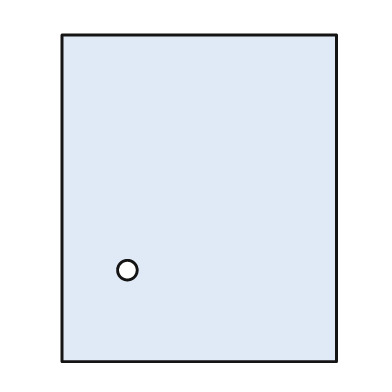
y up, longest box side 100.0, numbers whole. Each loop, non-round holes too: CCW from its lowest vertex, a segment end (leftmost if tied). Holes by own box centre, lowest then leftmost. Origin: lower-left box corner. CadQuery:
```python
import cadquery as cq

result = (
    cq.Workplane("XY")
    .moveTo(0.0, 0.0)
    .lineTo(84.0, 0.0)
    .lineTo(84.0, 100.0)
    .lineTo(0.0, 100.0)
    .close()
    .moveTo(20.0, 28.0)
    .circle(3.0)
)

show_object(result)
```